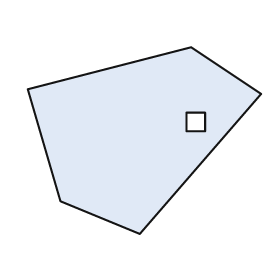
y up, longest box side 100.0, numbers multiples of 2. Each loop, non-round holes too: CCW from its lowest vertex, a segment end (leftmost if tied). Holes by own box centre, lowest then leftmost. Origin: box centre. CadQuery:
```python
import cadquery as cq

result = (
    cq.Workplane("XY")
    .moveTo(-2.0, -40.0)
    .lineTo(50.0, 20.0)
    .lineTo(20.0, 40.0)
    .lineTo(-50.0, 22.0)
    .lineTo(-36.0, -26.0)
    .close()
    .moveTo(18.0, 4.0)
    .lineTo(26.0, 4.0)
    .lineTo(26.0, 12.0)
    .lineTo(18.0, 12.0)
    .close()
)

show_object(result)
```